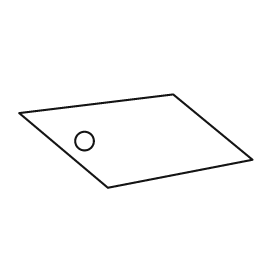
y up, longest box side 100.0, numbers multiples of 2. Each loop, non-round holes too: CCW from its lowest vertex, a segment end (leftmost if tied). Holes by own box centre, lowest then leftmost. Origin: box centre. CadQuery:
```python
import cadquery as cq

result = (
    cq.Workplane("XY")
    .moveTo(-12.0, -20.0)
    .lineTo(50.0, -8.0)
    .lineTo(16.0, 20.0)
    .lineTo(-50.0, 12.0)
    .close()
    .moveTo(-22.0, 0.0)
    .circle(4.0)
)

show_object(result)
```